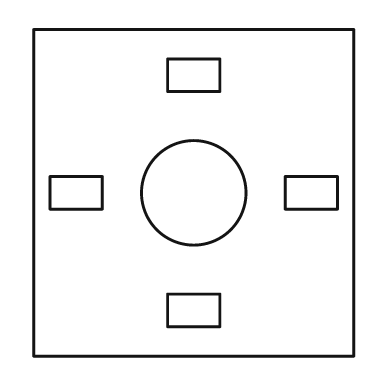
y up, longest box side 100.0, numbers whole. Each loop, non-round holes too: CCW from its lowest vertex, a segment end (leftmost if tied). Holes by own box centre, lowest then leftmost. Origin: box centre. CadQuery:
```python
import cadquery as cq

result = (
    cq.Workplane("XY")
    .moveTo(-49.0, -50.0)
    .lineTo(49.0, -50.0)
    .lineTo(49.0, 50.0)
    .lineTo(-49.0, 50.0)
    .close()
    .moveTo(-8.0, -41.0)
    .lineTo(8.0, -41.0)
    .lineTo(8.0, -31.0)
    .lineTo(-8.0, -31.0)
    .close()
    .moveTo(-44.0, -5.0)
    .lineTo(-28.0, -5.0)
    .lineTo(-28.0, 5.0)
    .lineTo(-44.0, 5.0)
    .close()
    .moveTo(0.0, 0.0)
    .circle(16.0)
    .moveTo(28.0, -5.0)
    .lineTo(44.0, -5.0)
    .lineTo(44.0, 5.0)
    .lineTo(28.0, 5.0)
    .close()
    .moveTo(-8.0, 31.0)
    .lineTo(8.0, 31.0)
    .lineTo(8.0, 41.0)
    .lineTo(-8.0, 41.0)
    .close()
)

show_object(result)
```